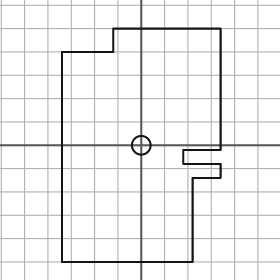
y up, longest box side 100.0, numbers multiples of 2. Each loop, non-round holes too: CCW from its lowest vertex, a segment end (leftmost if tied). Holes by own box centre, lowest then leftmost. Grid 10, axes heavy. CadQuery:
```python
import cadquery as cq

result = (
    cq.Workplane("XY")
    .moveTo(-34.0, -50.0)
    .lineTo(22.0, -50.0)
    .lineTo(22.0, -14.0)
    .lineTo(34.0, -14.0)
    .lineTo(34.0, -8.0)
    .lineTo(18.0, -8.0)
    .lineTo(18.0, -2.0)
    .lineTo(34.0, -2.0)
    .lineTo(34.0, 50.0)
    .lineTo(-12.0, 50.0)
    .lineTo(-12.0, 40.0)
    .lineTo(-34.0, 40.0)
    .close()
    .moveTo(0.0, 0.0)
    .circle(4.0)
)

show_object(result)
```